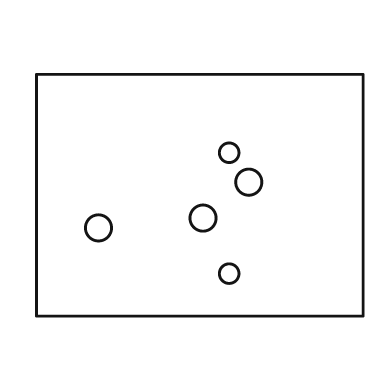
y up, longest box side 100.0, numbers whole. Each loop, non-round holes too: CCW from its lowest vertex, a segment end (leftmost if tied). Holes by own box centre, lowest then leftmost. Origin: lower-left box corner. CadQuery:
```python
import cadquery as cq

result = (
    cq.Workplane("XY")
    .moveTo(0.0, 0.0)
    .lineTo(100.0, 0.0)
    .lineTo(100.0, 74.0)
    .lineTo(0.0, 74.0)
    .close()
    .moveTo(59.0, 13.0)
    .circle(3.0)
    .moveTo(19.0, 27.0)
    .circle(4.0)
    .moveTo(51.0, 30.0)
    .circle(4.0)
    .moveTo(65.0, 41.0)
    .circle(4.0)
    .moveTo(59.0, 50.0)
    .circle(3.0)
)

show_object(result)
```